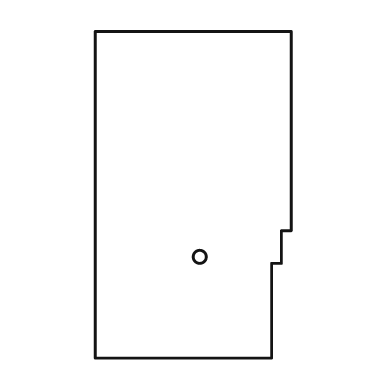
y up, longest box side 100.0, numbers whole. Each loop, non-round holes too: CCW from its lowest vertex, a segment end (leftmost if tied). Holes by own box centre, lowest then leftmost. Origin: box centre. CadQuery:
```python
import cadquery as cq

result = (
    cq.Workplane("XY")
    .moveTo(-30.0, -50.0)
    .lineTo(24.0, -50.0)
    .lineTo(24.0, -21.0)
    .lineTo(27.0, -21.0)
    .lineTo(27.0, -11.0)
    .lineTo(30.0, -11.0)
    .lineTo(30.0, 50.0)
    .lineTo(-30.0, 50.0)
    .close()
    .moveTo(2.0, -19.0)
    .circle(2.0)
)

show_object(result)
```